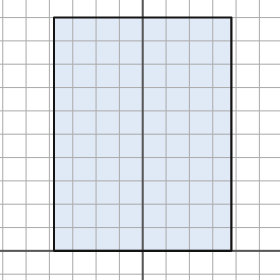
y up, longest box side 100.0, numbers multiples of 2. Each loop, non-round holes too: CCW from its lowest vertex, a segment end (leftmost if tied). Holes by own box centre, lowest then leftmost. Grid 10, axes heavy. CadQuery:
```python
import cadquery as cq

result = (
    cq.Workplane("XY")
    .moveTo(-38.0, 0.0)
    .lineTo(38.0, 0.0)
    .lineTo(38.0, 100.0)
    .lineTo(-38.0, 100.0)
    .close()
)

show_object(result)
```